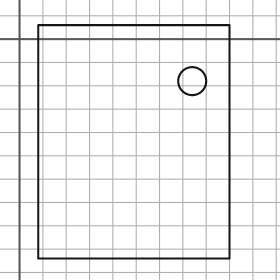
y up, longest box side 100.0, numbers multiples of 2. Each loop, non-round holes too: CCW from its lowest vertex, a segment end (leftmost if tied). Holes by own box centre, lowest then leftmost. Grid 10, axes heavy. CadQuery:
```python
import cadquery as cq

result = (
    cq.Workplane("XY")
    .moveTo(8.0, -94.0)
    .lineTo(90.0, -94.0)
    .lineTo(90.0, 6.0)
    .lineTo(8.0, 6.0)
    .close()
    .moveTo(74.0, -18.0)
    .circle(6.0)
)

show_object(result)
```